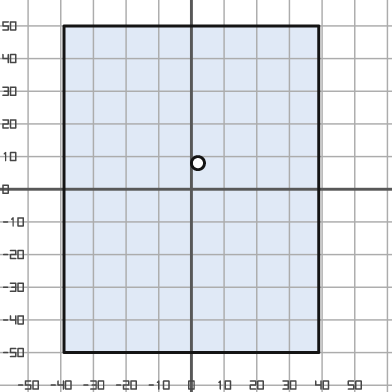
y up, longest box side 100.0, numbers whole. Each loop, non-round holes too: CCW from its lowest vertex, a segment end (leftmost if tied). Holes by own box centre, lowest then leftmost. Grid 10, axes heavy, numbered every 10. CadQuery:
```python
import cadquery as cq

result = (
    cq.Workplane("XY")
    .moveTo(-39.0, -50.0)
    .lineTo(39.0, -50.0)
    .lineTo(39.0, 50.0)
    .lineTo(-39.0, 50.0)
    .close()
    .moveTo(2.0, 8.0)
    .circle(2.0)
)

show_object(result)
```